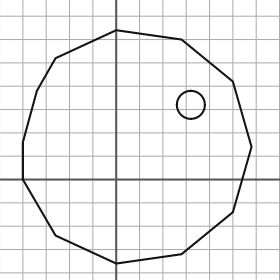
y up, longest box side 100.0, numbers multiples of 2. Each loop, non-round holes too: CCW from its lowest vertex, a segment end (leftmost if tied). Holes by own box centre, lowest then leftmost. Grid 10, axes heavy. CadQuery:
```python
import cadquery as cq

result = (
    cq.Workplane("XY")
    .moveTo(0.0, -36.0)
    .lineTo(28.0, -32.0)
    .lineTo(50.0, -14.0)
    .lineTo(58.0, 14.0)
    .lineTo(50.0, 42.0)
    .lineTo(28.0, 60.0)
    .lineTo(0.0, 64.0)
    .lineTo(-26.0, 52.0)
    .lineTo(-34.0, 38.0)
    .lineTo(-40.0, 16.0)
    .lineTo(-40.0, 0.0)
    .lineTo(-26.0, -24.0)
    .close()
    .moveTo(32.0, 32.0)
    .circle(6.0)
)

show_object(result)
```